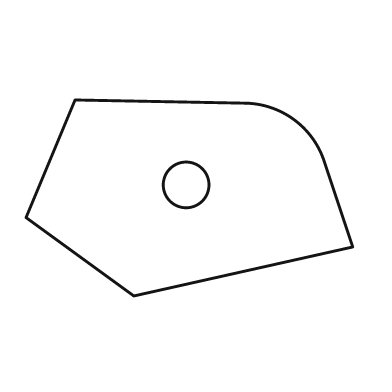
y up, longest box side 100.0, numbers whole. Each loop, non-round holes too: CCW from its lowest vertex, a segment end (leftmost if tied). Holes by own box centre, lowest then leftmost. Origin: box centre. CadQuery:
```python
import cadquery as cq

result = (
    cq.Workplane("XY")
    .moveTo(-17.0, -30.0)
    .lineTo(50.0, -15.0)
    .lineTo(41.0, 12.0)
    .threePointArc((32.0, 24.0), (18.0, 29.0))
    .lineTo(-35.0, 30.0)
    .lineTo(-50.0, -6.0)
    .close()
    .moveTo(-1.0, 4.0)
    .circle(7.0)
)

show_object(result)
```